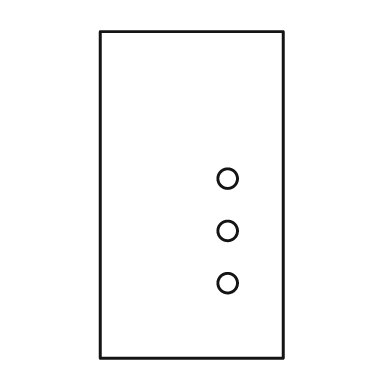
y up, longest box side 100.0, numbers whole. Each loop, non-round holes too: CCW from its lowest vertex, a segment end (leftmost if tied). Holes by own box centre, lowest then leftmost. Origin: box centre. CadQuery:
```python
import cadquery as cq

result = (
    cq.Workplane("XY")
    .moveTo(-28.0, -50.0)
    .lineTo(28.0, -50.0)
    .lineTo(28.0, 50.0)
    .lineTo(-28.0, 50.0)
    .close()
    .moveTo(11.0, -27.0)
    .circle(3.0)
    .moveTo(11.0, -11.0)
    .circle(3.0)
    .moveTo(11.0, 5.0)
    .circle(3.0)
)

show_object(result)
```